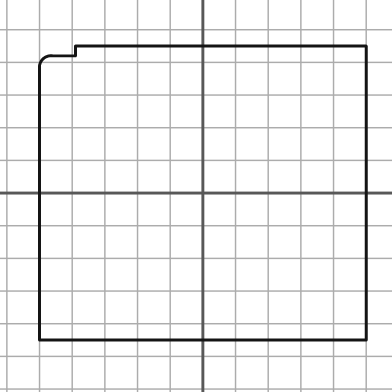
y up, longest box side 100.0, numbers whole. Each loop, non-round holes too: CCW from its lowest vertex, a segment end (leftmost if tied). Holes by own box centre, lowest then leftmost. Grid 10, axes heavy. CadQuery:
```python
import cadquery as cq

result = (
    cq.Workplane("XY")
    .moveTo(-50.0, -45.0)
    .lineTo(50.0, -45.0)
    .lineTo(50.0, 45.0)
    .lineTo(-39.0, 45.0)
    .lineTo(-39.0, 42.0)
    .lineTo(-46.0, 42.0)
    .threePointArc((-49.0, 41.0), (-50.0, 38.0))
    .close()
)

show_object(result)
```